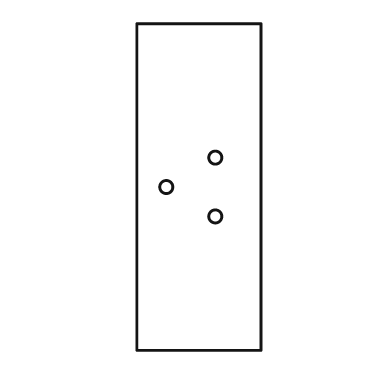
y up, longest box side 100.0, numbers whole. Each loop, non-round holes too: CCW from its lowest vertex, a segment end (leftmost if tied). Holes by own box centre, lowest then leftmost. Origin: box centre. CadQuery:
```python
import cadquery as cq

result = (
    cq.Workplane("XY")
    .moveTo(-19.0, -50.0)
    .lineTo(19.0, -50.0)
    .lineTo(19.0, 50.0)
    .lineTo(-19.0, 50.0)
    .close()
    .moveTo(5.0, -9.0)
    .circle(2.0)
    .moveTo(-10.0, 0.0)
    .circle(2.0)
    .moveTo(5.0, 9.0)
    .circle(2.0)
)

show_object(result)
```